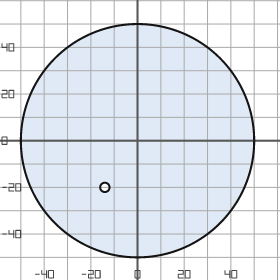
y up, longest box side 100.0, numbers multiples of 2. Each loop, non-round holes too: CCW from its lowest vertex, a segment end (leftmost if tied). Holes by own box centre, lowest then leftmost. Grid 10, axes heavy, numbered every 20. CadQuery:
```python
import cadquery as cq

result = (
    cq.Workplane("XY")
    .moveTo(0.0, 0.0)
    .circle(50.0)
    .moveTo(-14.0, -20.0)
    .circle(2.0)
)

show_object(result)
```